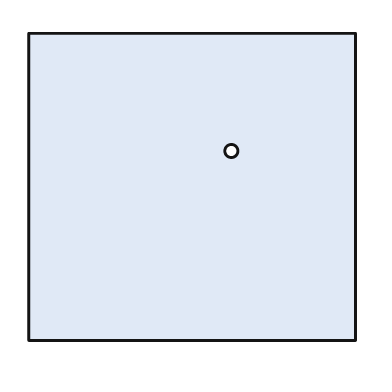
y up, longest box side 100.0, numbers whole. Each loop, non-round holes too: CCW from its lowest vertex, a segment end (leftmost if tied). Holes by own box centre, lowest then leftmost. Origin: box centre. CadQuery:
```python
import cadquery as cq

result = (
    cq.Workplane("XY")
    .moveTo(-50.0, -47.0)
    .lineTo(50.0, -47.0)
    .lineTo(50.0, 47.0)
    .lineTo(-50.0, 47.0)
    .close()
    .moveTo(12.0, 11.0)
    .circle(2.0)
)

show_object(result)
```